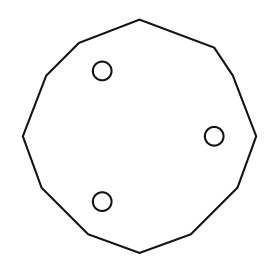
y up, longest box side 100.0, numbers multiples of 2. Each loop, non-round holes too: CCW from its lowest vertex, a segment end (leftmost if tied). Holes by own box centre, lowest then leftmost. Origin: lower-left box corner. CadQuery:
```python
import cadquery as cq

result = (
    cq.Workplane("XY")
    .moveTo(50.0, 0.0)
    .lineTo(72.0, 8.0)
    .lineTo(92.0, 28.0)
    .lineTo(100.0, 50.0)
    .lineTo(90.0, 76.0)
    .lineTo(82.0, 88.0)
    .lineTo(50.0, 100.0)
    .lineTo(24.0, 90.0)
    .lineTo(10.0, 76.0)
    .lineTo(0.0, 50.0)
    .lineTo(8.0, 28.0)
    .lineTo(28.0, 8.0)
    .close()
    .moveTo(34.0, 22.0)
    .circle(4.0)
    .moveTo(82.0, 50.0)
    .circle(4.0)
    .moveTo(34.0, 78.0)
    .circle(4.0)
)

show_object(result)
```